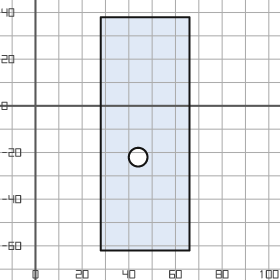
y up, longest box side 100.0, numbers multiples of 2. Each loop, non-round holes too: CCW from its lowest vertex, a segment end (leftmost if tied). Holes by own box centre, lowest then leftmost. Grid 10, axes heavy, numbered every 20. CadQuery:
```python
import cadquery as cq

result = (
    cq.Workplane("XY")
    .moveTo(28.0, -62.0)
    .lineTo(66.0, -62.0)
    .lineTo(66.0, 38.0)
    .lineTo(28.0, 38.0)
    .close()
    .moveTo(44.0, -22.0)
    .circle(4.0)
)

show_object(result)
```